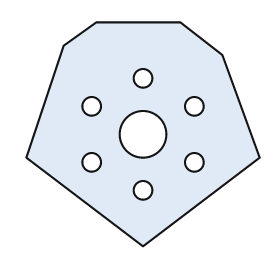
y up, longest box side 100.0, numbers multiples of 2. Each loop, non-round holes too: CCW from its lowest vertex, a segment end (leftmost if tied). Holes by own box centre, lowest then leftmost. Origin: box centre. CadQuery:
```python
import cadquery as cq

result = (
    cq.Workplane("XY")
    .moveTo(0.0, -48.0)
    .lineTo(50.0, -10.0)
    .lineTo(34.0, 34.0)
    .lineTo(16.0, 48.0)
    .lineTo(-20.0, 48.0)
    .lineTo(-34.0, 38.0)
    .lineTo(-50.0, -10.0)
    .close()
    .moveTo(0.0, -24.0)
    .circle(4.0)
    .moveTo(-22.0, -12.0)
    .circle(4.0)
    .moveTo(22.0, -12.0)
    .circle(4.0)
    .moveTo(0.0, 0.0)
    .circle(10.0)
    .moveTo(-22.0, 12.0)
    .circle(4.0)
    .moveTo(22.0, 12.0)
    .circle(4.0)
    .moveTo(0.0, 24.0)
    .circle(4.0)
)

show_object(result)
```